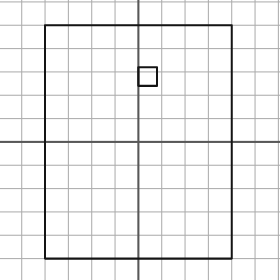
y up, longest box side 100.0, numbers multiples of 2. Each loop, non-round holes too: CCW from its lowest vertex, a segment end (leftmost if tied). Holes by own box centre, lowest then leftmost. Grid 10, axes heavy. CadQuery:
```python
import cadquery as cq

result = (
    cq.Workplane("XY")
    .moveTo(-40.0, -50.0)
    .lineTo(40.0, -50.0)
    .lineTo(40.0, 50.0)
    .lineTo(-40.0, 50.0)
    .close()
    .moveTo(0.0, 24.0)
    .lineTo(8.0, 24.0)
    .lineTo(8.0, 32.0)
    .lineTo(0.0, 32.0)
    .close()
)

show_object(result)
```